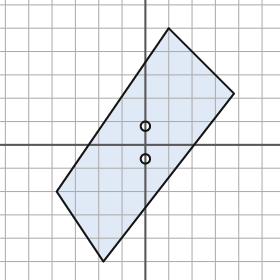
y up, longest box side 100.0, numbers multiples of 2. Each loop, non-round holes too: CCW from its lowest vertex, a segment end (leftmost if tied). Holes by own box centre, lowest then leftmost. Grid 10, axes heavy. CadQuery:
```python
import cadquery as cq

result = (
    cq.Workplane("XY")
    .moveTo(-18.0, -50.0)
    .lineTo(38.0, 22.0)
    .lineTo(10.0, 50.0)
    .lineTo(-38.0, -20.0)
    .close()
    .moveTo(0.0, -6.0)
    .circle(2.0)
    .moveTo(0.0, 8.0)
    .circle(2.0)
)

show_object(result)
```